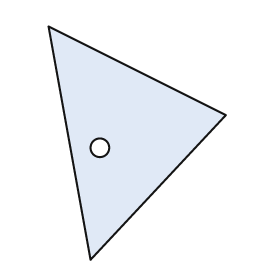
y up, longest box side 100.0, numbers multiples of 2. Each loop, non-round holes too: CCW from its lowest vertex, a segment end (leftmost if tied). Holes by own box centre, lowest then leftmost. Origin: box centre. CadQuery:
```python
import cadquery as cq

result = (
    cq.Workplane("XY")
    .moveTo(-20.0, -50.0)
    .lineTo(38.0, 12.0)
    .lineTo(-38.0, 50.0)
    .close()
    .moveTo(-16.0, -2.0)
    .circle(4.0)
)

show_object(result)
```